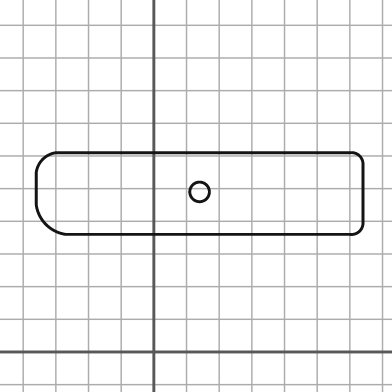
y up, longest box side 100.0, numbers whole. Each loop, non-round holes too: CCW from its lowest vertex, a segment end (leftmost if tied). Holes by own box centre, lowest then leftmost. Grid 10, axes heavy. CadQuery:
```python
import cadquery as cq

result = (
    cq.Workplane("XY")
    .moveTo(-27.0, 36.0)
    .lineTo(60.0, 36.0)
    .threePointArc((63.0, 37.0), (64.0, 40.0))
    .lineTo(64.0, 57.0)
    .threePointArc((63.0, 60.0), (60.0, 61.0))
    .lineTo(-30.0, 61.0)
    .threePointArc((-34.0, 59.0), (-36.0, 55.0))
    .lineTo(-36.0, 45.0)
    .threePointArc((-33.0, 39.0), (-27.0, 36.0))
    .close()
    .moveTo(14.0, 49.0)
    .circle(3.0)
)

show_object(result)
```